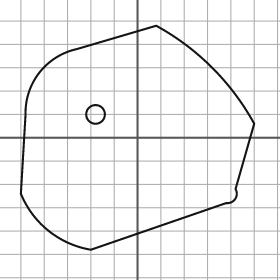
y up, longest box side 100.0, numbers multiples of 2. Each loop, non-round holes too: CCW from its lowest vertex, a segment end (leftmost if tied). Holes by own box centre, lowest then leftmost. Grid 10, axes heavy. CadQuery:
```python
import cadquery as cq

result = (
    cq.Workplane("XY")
    .moveTo(-20.0, -48.0)
    .lineTo(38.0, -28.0)
    .threePointArc((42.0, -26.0), (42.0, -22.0))
    .lineTo(50.0, 6.0)
    .threePointArc((32.0, 30.0), (8.0, 48.0))
    .lineTo(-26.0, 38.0)
    .threePointArc((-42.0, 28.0), (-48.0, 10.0))
    .lineTo(-50.0, -24.0)
    .threePointArc((-38.0, -40.0), (-20.0, -48.0))
    .close()
    .moveTo(-18.0, 10.0)
    .circle(4.0)
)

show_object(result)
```